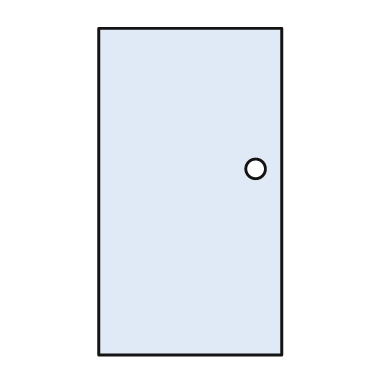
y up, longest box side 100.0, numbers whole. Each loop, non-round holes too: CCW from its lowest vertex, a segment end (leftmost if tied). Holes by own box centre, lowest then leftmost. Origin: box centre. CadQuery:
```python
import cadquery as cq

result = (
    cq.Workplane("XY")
    .moveTo(-28.0, -50.0)
    .lineTo(28.0, -50.0)
    .lineTo(28.0, 50.0)
    .lineTo(-28.0, 50.0)
    .close()
    .moveTo(20.0, 7.0)
    .circle(3.0)
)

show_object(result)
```